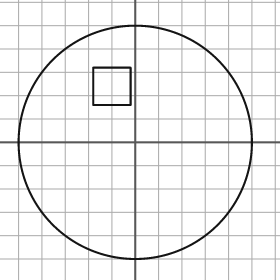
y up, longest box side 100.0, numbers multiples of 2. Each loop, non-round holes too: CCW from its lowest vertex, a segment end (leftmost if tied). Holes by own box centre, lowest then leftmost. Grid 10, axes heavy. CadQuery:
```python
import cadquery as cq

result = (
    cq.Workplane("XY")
    .moveTo(0.0, 0.0)
    .circle(50.0)
    .moveTo(-18.0, 16.0)
    .lineTo(-2.0, 16.0)
    .lineTo(-2.0, 32.0)
    .lineTo(-18.0, 32.0)
    .close()
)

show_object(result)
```